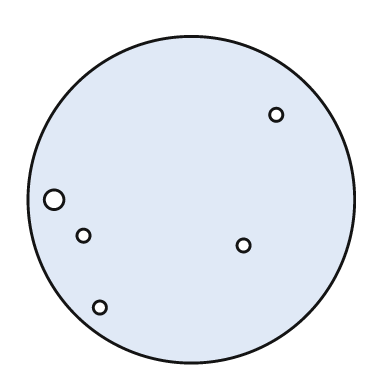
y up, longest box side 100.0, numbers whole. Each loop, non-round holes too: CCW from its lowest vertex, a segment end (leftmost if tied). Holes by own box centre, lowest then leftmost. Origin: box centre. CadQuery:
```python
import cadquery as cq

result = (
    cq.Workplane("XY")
    .moveTo(0.0, 0.0)
    .circle(50.0)
    .moveTo(-28.0, -33.0)
    .circle(2.0)
    .moveTo(16.0, -14.0)
    .circle(2.0)
    .moveTo(-33.0, -11.0)
    .circle(2.0)
    .moveTo(-42.0, 0.0)
    .circle(3.0)
    .moveTo(26.0, 26.0)
    .circle(2.0)
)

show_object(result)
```